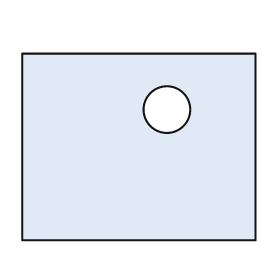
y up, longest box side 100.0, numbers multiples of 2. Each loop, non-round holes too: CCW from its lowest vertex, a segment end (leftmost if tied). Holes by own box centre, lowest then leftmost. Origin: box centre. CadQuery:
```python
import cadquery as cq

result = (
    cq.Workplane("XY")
    .moveTo(-50.0, -40.0)
    .lineTo(50.0, -40.0)
    .lineTo(50.0, 40.0)
    .lineTo(-50.0, 40.0)
    .close()
    .moveTo(12.0, 16.0)
    .circle(10.0)
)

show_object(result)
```